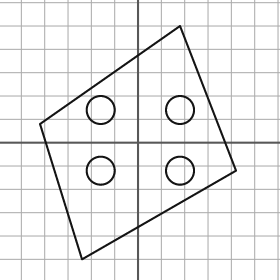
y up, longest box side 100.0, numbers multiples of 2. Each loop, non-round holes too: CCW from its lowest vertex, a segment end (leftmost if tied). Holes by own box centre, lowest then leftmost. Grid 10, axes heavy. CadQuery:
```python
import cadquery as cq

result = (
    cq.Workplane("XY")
    .moveTo(-24.0, -50.0)
    .lineTo(42.0, -12.0)
    .lineTo(18.0, 50.0)
    .lineTo(-42.0, 8.0)
    .close()
    .moveTo(-16.0, -12.0)
    .circle(6.0)
    .moveTo(18.0, -12.0)
    .circle(6.0)
    .moveTo(-16.0, 14.0)
    .circle(6.0)
    .moveTo(18.0, 14.0)
    .circle(6.0)
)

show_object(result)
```